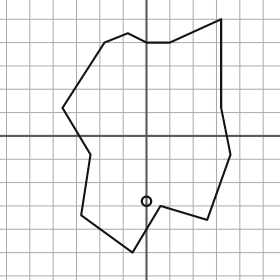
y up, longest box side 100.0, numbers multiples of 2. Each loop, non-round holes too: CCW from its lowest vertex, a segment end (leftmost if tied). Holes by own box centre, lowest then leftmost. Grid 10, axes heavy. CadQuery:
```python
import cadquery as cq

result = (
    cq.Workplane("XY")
    .moveTo(-6.0, -50.0)
    .lineTo(6.0, -30.0)
    .lineTo(26.0, -36.0)
    .lineTo(36.0, -8.0)
    .lineTo(32.0, 12.0)
    .lineTo(32.0, 50.0)
    .lineTo(10.0, 40.0)
    .lineTo(0.0, 40.0)
    .lineTo(-8.0, 44.0)
    .lineTo(-18.0, 40.0)
    .lineTo(-36.0, 12.0)
    .lineTo(-24.0, -8.0)
    .lineTo(-28.0, -34.0)
    .close()
    .moveTo(0.0, -28.0)
    .circle(2.0)
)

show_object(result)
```